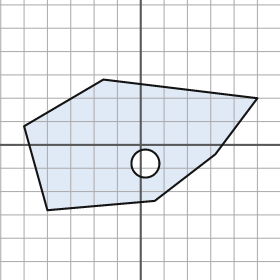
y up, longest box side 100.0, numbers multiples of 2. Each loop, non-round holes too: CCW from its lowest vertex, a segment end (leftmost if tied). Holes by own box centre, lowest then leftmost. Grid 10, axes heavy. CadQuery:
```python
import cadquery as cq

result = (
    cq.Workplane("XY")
    .moveTo(-40.0, -28.0)
    .lineTo(6.0, -24.0)
    .lineTo(32.0, -4.0)
    .lineTo(50.0, 20.0)
    .lineTo(-16.0, 28.0)
    .lineTo(-50.0, 8.0)
    .close()
    .moveTo(2.0, -8.0)
    .circle(6.0)
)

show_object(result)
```